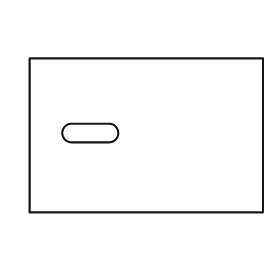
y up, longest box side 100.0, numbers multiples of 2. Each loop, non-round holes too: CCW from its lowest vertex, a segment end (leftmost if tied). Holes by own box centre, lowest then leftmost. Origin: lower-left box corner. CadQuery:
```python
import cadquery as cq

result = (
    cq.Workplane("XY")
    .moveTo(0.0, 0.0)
    .lineTo(100.0, 0.0)
    .lineTo(100.0, 66.0)
    .lineTo(0.0, 66.0)
    .close()
    .moveTo(18.0, 30.0)
    .lineTo(34.0, 30.0)
    .threePointArc((38.0, 34.0), (34.0, 38.0))
    .lineTo(18.0, 38.0)
    .threePointArc((14.0, 34.0), (18.0, 30.0))
    .close()
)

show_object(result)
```